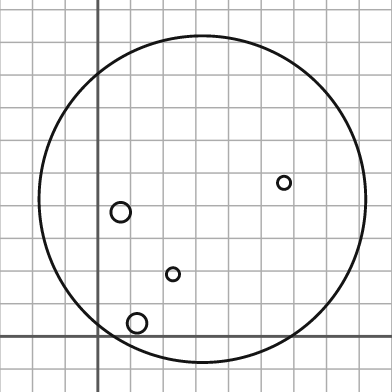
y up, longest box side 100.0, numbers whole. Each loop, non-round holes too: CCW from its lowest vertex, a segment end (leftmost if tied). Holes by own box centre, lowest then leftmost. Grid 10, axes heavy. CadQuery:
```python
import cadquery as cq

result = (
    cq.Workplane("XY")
    .moveTo(32.0, 42.0)
    .circle(50.0)
    .moveTo(12.0, 4.0)
    .circle(3.0)
    .moveTo(23.0, 19.0)
    .circle(2.0)
    .moveTo(7.0, 38.0)
    .circle(3.0)
    .moveTo(57.0, 47.0)
    .circle(2.0)
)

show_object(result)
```